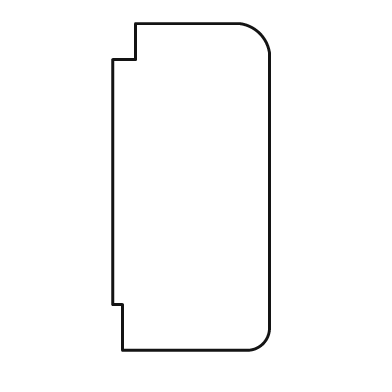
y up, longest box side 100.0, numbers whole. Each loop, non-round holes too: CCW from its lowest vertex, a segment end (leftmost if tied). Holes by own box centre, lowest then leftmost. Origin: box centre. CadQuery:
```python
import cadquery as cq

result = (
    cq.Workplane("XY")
    .moveTo(-21.0, -50.0)
    .lineTo(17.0, -50.0)
    .threePointArc((22.0, -48.0), (24.0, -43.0))
    .lineTo(24.0, 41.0)
    .threePointArc((21.0, 47.0), (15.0, 50.0))
    .lineTo(-17.0, 50.0)
    .lineTo(-17.0, 39.0)
    .lineTo(-24.0, 39.0)
    .lineTo(-24.0, -36.0)
    .lineTo(-21.0, -36.0)
    .close()
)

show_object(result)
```